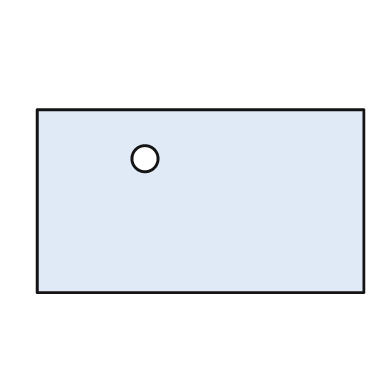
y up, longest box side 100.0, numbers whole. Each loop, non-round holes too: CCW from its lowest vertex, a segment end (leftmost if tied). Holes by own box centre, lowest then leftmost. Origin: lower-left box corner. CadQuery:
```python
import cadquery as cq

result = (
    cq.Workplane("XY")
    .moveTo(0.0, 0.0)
    .lineTo(100.0, 0.0)
    .lineTo(100.0, 56.0)
    .lineTo(0.0, 56.0)
    .close()
    .moveTo(33.0, 41.0)
    .circle(4.0)
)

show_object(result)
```